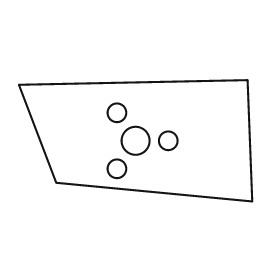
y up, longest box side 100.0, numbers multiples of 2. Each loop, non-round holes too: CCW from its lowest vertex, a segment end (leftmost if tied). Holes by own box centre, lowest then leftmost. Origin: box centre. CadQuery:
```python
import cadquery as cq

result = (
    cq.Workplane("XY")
    .moveTo(50.0, -26.0)
    .lineTo(48.0, 26.0)
    .lineTo(-50.0, 24.0)
    .lineTo(-34.0, -18.0)
    .close()
    .moveTo(-8.0, -12.0)
    .circle(4.0)
    .moveTo(0.0, 0.0)
    .circle(6.0)
    .moveTo(14.0, 0.0)
    .circle(4.0)
    .moveTo(-8.0, 12.0)
    .circle(4.0)
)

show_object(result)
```